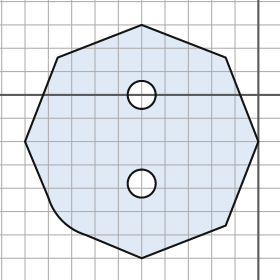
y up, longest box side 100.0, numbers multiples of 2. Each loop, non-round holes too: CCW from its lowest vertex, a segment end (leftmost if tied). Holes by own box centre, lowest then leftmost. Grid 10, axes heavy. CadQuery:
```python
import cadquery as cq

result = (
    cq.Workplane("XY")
    .moveTo(-50.0, -70.0)
    .lineTo(-14.0, -56.0)
    .lineTo(0.0, -20.0)
    .lineTo(-14.0, 16.0)
    .lineTo(-50.0, 30.0)
    .lineTo(-86.0, 16.0)
    .lineTo(-100.0, -20.0)
    .lineTo(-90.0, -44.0)
    .threePointArc((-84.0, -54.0), (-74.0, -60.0))
    .close()
    .moveTo(-50.0, -38.0)
    .circle(6.0)
    .moveTo(-50.0, 0.0)
    .circle(6.0)
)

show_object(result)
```